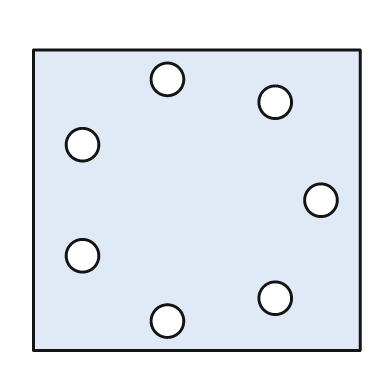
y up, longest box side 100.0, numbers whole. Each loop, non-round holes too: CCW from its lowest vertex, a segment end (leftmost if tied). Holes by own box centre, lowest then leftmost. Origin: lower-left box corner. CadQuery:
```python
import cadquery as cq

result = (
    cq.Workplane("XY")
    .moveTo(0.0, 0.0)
    .lineTo(100.0, 0.0)
    .lineTo(100.0, 92.0)
    .lineTo(0.0, 92.0)
    .close()
    .moveTo(41.0, 9.0)
    .circle(5.0)
    .moveTo(74.0, 16.0)
    .circle(5.0)
    .moveTo(15.0, 29.0)
    .circle(5.0)
    .moveTo(88.0, 46.0)
    .circle(5.0)
    .moveTo(15.0, 63.0)
    .circle(5.0)
    .moveTo(74.0, 76.0)
    .circle(5.0)
    .moveTo(41.0, 83.0)
    .circle(5.0)
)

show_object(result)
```